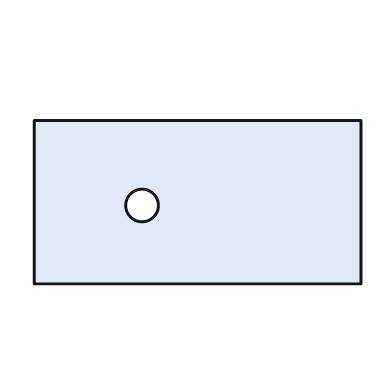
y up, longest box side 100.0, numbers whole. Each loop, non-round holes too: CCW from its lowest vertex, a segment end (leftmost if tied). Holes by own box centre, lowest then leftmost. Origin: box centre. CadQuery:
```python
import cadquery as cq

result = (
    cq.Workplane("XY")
    .moveTo(-50.0, -25.0)
    .lineTo(50.0, -25.0)
    .lineTo(50.0, 25.0)
    .lineTo(-50.0, 25.0)
    .close()
    .moveTo(-17.0, -1.0)
    .circle(5.0)
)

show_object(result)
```